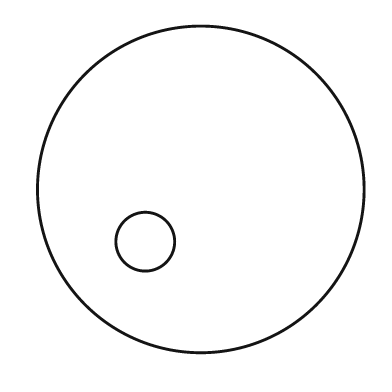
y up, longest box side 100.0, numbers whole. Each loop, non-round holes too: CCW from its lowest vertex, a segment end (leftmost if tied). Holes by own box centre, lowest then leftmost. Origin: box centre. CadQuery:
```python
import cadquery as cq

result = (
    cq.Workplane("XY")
    .moveTo(0.0, 0.0)
    .circle(50.0)
    .moveTo(-17.0, -16.0)
    .circle(9.0)
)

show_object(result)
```